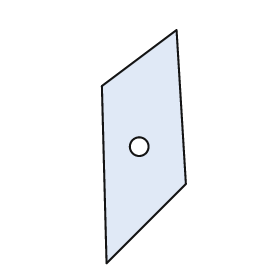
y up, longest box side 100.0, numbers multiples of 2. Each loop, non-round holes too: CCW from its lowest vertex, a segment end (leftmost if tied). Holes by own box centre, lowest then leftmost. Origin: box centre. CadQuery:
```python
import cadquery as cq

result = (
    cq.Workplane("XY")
    .moveTo(-16.0, -50.0)
    .lineTo(18.0, -16.0)
    .lineTo(14.0, 50.0)
    .lineTo(-18.0, 26.0)
    .close()
    .moveTo(-2.0, 0.0)
    .circle(4.0)
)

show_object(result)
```